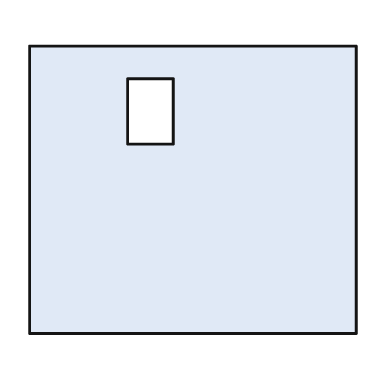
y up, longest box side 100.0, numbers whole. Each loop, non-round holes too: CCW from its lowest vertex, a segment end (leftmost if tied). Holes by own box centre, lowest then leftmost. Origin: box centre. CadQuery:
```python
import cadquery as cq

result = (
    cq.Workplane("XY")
    .moveTo(-50.0, -44.0)
    .lineTo(50.0, -44.0)
    .lineTo(50.0, 44.0)
    .lineTo(-50.0, 44.0)
    .close()
    .moveTo(-20.0, 14.0)
    .lineTo(-6.0, 14.0)
    .lineTo(-6.0, 34.0)
    .lineTo(-20.0, 34.0)
    .close()
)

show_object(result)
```